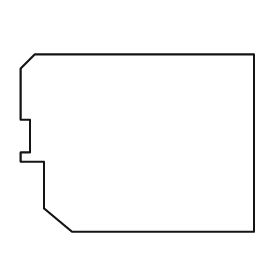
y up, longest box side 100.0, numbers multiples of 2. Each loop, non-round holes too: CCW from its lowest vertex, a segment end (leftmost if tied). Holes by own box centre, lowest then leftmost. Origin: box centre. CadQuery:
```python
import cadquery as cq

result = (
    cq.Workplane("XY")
    .moveTo(-28.0, -38.0)
    .lineTo(50.0, -38.0)
    .lineTo(50.0, 38.0)
    .lineTo(-44.0, 38.0)
    .lineTo(-50.0, 32.0)
    .lineTo(-50.0, 10.0)
    .lineTo(-46.0, 10.0)
    .lineTo(-46.0, -4.0)
    .lineTo(-50.0, -4.0)
    .lineTo(-50.0, -8.0)
    .lineTo(-40.0, -8.0)
    .lineTo(-40.0, -28.0)
    .close()
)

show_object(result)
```